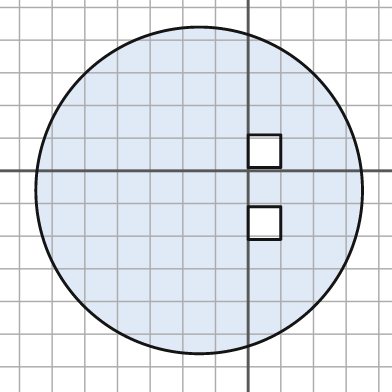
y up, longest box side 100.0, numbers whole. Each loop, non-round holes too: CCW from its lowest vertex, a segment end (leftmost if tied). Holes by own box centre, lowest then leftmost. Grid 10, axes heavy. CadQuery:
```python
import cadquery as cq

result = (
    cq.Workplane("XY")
    .moveTo(-15.0, -6.0)
    .circle(50.0)
    .moveTo(0.0, -21.0)
    .lineTo(10.0, -21.0)
    .lineTo(10.0, -11.0)
    .lineTo(0.0, -11.0)
    .close()
    .moveTo(0.0, 1.0)
    .lineTo(10.0, 1.0)
    .lineTo(10.0, 11.0)
    .lineTo(0.0, 11.0)
    .close()
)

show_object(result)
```